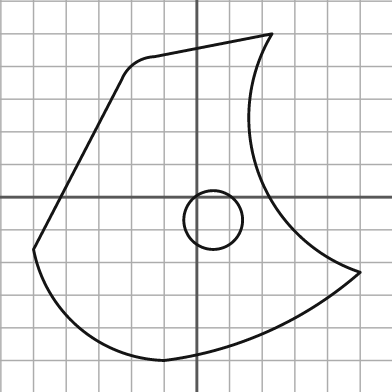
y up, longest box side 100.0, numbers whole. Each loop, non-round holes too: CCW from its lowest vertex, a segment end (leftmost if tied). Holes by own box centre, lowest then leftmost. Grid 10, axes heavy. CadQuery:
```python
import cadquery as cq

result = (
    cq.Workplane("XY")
    .moveTo(-10.0, -50.0)
    .threePointArc((22.0, -41.0), (50.0, -23.0))
    .threePointArc((19.0, 7.0), (23.0, 50.0))
    .lineTo(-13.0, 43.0)
    .threePointArc((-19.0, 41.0), (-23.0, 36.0))
    .lineTo(-50.0, -16.0)
    .threePointArc((-36.0, -40.0), (-10.0, -50.0))
    .close()
    .moveTo(5.0, -7.0)
    .circle(9.0)
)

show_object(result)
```